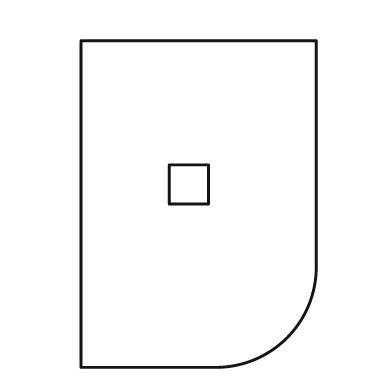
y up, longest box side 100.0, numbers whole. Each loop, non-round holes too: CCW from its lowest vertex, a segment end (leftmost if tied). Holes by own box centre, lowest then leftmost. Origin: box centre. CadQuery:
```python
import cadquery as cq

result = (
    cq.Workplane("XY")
    .moveTo(-36.0, -50.0)
    .lineTo(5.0, -50.0)
    .threePointArc((27.0, -41.0), (36.0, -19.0))
    .lineTo(36.0, 50.0)
    .lineTo(-36.0, 50.0)
    .close()
    .moveTo(-9.0, 0.0)
    .lineTo(3.0, 0.0)
    .lineTo(3.0, 12.0)
    .lineTo(-9.0, 12.0)
    .close()
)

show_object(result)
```